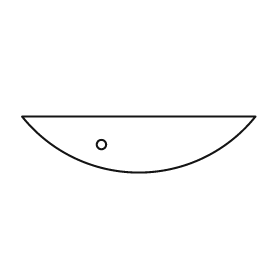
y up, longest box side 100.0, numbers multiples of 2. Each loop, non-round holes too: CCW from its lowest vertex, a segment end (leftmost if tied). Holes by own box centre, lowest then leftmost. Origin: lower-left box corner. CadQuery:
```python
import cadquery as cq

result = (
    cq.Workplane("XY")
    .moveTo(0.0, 24.0)
    .threePointArc((50.0, 0.0), (100.0, 24.0))
    .close()
    .moveTo(34.0, 12.0)
    .circle(2.0)
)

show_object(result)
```